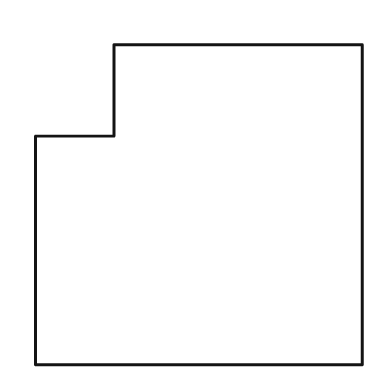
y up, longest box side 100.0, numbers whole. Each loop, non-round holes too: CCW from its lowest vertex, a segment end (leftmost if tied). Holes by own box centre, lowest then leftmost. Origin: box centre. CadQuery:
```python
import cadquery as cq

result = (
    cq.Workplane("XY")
    .moveTo(-50.0, -49.0)
    .lineTo(50.0, -49.0)
    .lineTo(50.0, 49.0)
    .lineTo(-26.0, 49.0)
    .lineTo(-26.0, 21.0)
    .lineTo(-50.0, 21.0)
    .close()
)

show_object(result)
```